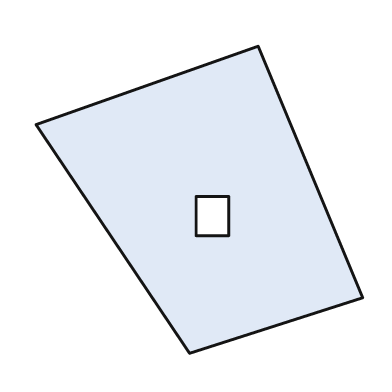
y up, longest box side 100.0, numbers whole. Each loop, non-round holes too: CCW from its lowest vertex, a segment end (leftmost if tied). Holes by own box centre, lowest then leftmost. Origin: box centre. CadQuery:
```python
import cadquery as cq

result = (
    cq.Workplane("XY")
    .moveTo(-3.0, -47.0)
    .lineTo(50.0, -30.0)
    .lineTo(18.0, 47.0)
    .lineTo(-50.0, 23.0)
    .close()
    .moveTo(-1.0, -11.0)
    .lineTo(9.0, -11.0)
    .lineTo(9.0, 1.0)
    .lineTo(-1.0, 1.0)
    .close()
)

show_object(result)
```